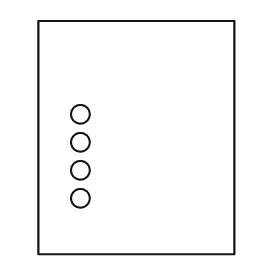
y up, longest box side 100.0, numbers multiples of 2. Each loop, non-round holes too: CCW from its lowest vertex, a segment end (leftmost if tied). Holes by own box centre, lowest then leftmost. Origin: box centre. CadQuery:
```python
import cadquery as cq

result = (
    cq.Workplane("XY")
    .moveTo(-42.0, -50.0)
    .lineTo(42.0, -50.0)
    .lineTo(42.0, 50.0)
    .lineTo(-42.0, 50.0)
    .close()
    .moveTo(-24.0, -26.0)
    .circle(4.0)
    .moveTo(-24.0, -14.0)
    .circle(4.0)
    .moveTo(-24.0, -2.0)
    .circle(4.0)
    .moveTo(-24.0, 10.0)
    .circle(4.0)
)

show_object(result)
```